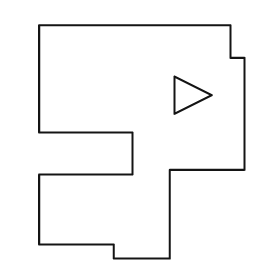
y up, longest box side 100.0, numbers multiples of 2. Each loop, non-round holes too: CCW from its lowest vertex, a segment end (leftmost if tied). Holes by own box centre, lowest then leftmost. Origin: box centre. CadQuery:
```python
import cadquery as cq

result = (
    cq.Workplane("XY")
    .moveTo(-12.0, -50.0)
    .lineTo(12.0, -50.0)
    .lineTo(12.0, -12.0)
    .lineTo(44.0, -12.0)
    .lineTo(44.0, 36.0)
    .lineTo(38.0, 36.0)
    .lineTo(38.0, 50.0)
    .lineTo(-44.0, 50.0)
    .lineTo(-44.0, 4.0)
    .lineTo(-4.0, 4.0)
    .lineTo(-4.0, -14.0)
    .lineTo(-44.0, -14.0)
    .lineTo(-44.0, -44.0)
    .lineTo(-12.0, -44.0)
    .close()
    .moveTo(14.0, 12.0)
    .lineTo(30.0, 20.0)
    .lineTo(14.0, 28.0)
    .close()
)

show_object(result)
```